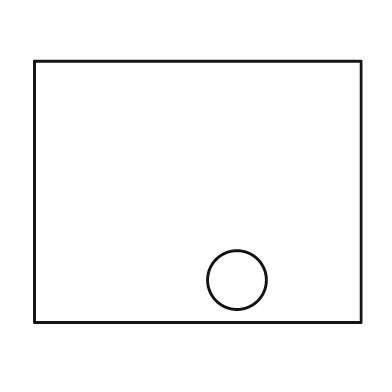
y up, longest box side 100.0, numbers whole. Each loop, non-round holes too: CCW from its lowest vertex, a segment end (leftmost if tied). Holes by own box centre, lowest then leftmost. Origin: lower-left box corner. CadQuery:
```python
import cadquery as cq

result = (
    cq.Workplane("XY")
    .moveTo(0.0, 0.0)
    .lineTo(100.0, 0.0)
    .lineTo(100.0, 80.0)
    .lineTo(0.0, 80.0)
    .close()
    .moveTo(62.0, 13.0)
    .circle(9.0)
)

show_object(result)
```